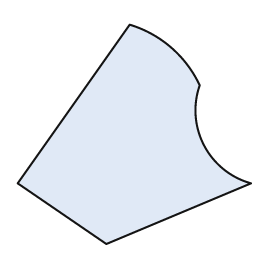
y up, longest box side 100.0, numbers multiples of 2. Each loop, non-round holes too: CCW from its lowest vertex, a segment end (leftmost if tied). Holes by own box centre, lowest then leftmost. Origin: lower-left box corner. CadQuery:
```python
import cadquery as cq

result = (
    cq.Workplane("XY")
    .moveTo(38.0, 0.0)
    .lineTo(100.0, 26.0)
    .threePointArc((80.0, 42.0), (78.0, 68.0))
    .threePointArc((66.0, 84.0), (48.0, 94.0))
    .lineTo(0.0, 26.0)
    .close()
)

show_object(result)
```